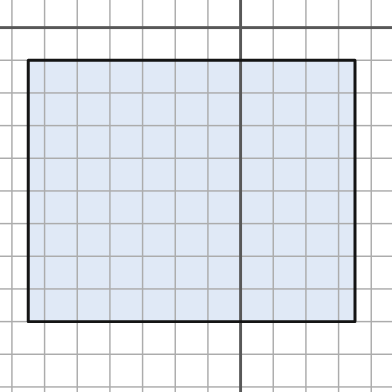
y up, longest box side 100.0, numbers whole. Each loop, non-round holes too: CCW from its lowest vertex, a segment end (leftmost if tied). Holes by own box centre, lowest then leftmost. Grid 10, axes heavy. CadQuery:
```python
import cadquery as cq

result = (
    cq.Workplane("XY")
    .moveTo(-65.0, -90.0)
    .lineTo(35.0, -90.0)
    .lineTo(35.0, -10.0)
    .lineTo(-65.0, -10.0)
    .close()
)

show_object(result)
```